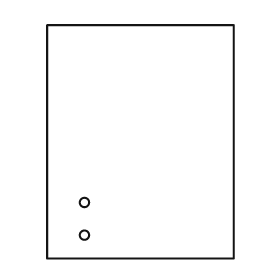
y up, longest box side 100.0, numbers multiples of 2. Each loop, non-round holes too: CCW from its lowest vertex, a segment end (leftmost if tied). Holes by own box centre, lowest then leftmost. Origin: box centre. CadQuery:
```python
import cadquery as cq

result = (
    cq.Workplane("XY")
    .moveTo(-40.0, -50.0)
    .lineTo(40.0, -50.0)
    .lineTo(40.0, 50.0)
    .lineTo(-40.0, 50.0)
    .close()
    .moveTo(-24.0, -40.0)
    .circle(2.0)
    .moveTo(-24.0, -26.0)
    .circle(2.0)
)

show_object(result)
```